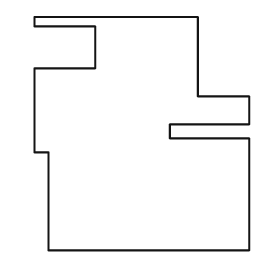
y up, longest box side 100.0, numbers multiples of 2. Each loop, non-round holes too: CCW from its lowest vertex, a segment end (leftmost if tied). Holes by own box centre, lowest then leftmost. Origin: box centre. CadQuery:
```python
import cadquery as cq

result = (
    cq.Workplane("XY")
    .moveTo(-40.0, -50.0)
    .lineTo(46.0, -50.0)
    .lineTo(46.0, -2.0)
    .lineTo(12.0, -2.0)
    .lineTo(12.0, 4.0)
    .lineTo(46.0, 4.0)
    .lineTo(46.0, 16.0)
    .lineTo(24.0, 16.0)
    .lineTo(24.0, 50.0)
    .lineTo(-46.0, 50.0)
    .lineTo(-46.0, 46.0)
    .lineTo(-20.0, 46.0)
    .lineTo(-20.0, 28.0)
    .lineTo(-46.0, 28.0)
    .lineTo(-46.0, -8.0)
    .lineTo(-40.0, -8.0)
    .close()
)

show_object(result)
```